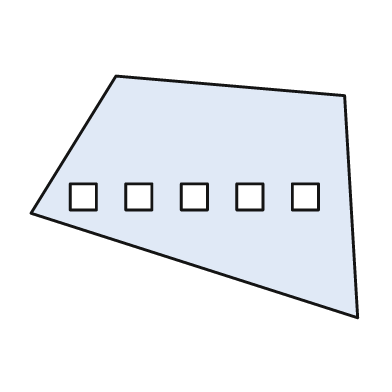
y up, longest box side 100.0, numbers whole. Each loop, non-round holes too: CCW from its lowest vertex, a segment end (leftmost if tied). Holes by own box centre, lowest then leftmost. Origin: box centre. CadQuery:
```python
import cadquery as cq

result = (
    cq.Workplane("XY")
    .moveTo(50.0, -37.0)
    .lineTo(46.0, 31.0)
    .lineTo(-24.0, 37.0)
    .lineTo(-50.0, -5.0)
    .close()
    .moveTo(-38.0, -4.0)
    .lineTo(-30.0, -4.0)
    .lineTo(-30.0, 4.0)
    .lineTo(-38.0, 4.0)
    .close()
    .moveTo(-21.0, -4.0)
    .lineTo(-13.0, -4.0)
    .lineTo(-13.0, 4.0)
    .lineTo(-21.0, 4.0)
    .close()
    .moveTo(-4.0, -4.0)
    .lineTo(4.0, -4.0)
    .lineTo(4.0, 4.0)
    .lineTo(-4.0, 4.0)
    .close()
    .moveTo(13.0, -4.0)
    .lineTo(21.0, -4.0)
    .lineTo(21.0, 4.0)
    .lineTo(13.0, 4.0)
    .close()
    .moveTo(30.0, -4.0)
    .lineTo(38.0, -4.0)
    .lineTo(38.0, 4.0)
    .lineTo(30.0, 4.0)
    .close()
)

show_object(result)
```